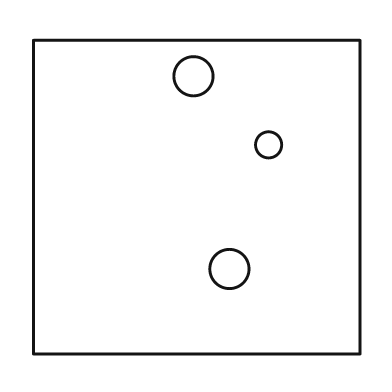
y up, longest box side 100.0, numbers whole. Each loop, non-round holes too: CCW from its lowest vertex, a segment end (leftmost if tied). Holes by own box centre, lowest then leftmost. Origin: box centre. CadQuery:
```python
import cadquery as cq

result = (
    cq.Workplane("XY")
    .moveTo(-50.0, -48.0)
    .lineTo(50.0, -48.0)
    .lineTo(50.0, 48.0)
    .lineTo(-50.0, 48.0)
    .close()
    .moveTo(10.0, -22.0)
    .circle(6.0)
    .moveTo(22.0, 16.0)
    .circle(4.0)
    .moveTo(-1.0, 37.0)
    .circle(6.0)
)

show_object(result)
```